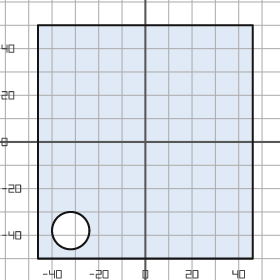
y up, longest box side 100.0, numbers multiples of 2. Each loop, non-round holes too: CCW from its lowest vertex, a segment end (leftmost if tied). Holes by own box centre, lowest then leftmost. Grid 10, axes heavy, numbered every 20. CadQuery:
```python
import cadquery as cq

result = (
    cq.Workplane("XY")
    .moveTo(-46.0, -50.0)
    .lineTo(46.0, -50.0)
    .lineTo(46.0, 50.0)
    .lineTo(-46.0, 50.0)
    .close()
    .moveTo(-32.0, -38.0)
    .circle(8.0)
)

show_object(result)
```